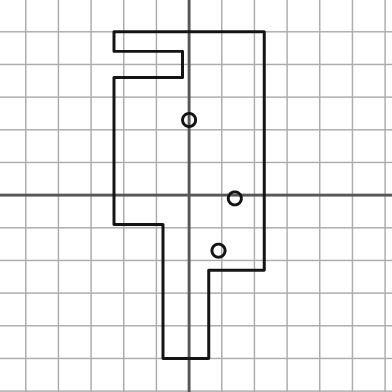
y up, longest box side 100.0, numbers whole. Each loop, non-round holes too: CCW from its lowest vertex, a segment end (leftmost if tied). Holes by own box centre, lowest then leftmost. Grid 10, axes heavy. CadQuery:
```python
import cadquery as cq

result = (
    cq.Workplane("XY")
    .moveTo(-8.0, -50.0)
    .lineTo(6.0, -50.0)
    .lineTo(6.0, -23.0)
    .lineTo(23.0, -23.0)
    .lineTo(23.0, 50.0)
    .lineTo(-23.0, 50.0)
    .lineTo(-23.0, 44.0)
    .lineTo(-2.0, 44.0)
    .lineTo(-2.0, 36.0)
    .lineTo(-23.0, 36.0)
    .lineTo(-23.0, -9.0)
    .lineTo(-8.0, -9.0)
    .close()
    .moveTo(9.0, -17.0)
    .circle(2.0)
    .moveTo(14.0, -1.0)
    .circle(2.0)
    .moveTo(0.0, 23.0)
    .circle(2.0)
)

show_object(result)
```